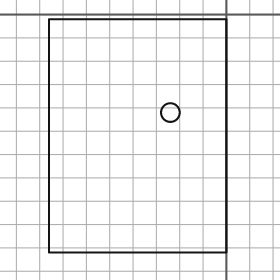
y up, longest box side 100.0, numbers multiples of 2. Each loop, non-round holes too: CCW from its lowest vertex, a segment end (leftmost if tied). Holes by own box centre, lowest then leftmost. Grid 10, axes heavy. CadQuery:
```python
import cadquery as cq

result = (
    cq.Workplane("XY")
    .moveTo(-76.0, -102.0)
    .lineTo(0.0, -102.0)
    .lineTo(0.0, -2.0)
    .lineTo(-76.0, -2.0)
    .close()
    .moveTo(-24.0, -42.0)
    .circle(4.0)
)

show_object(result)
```